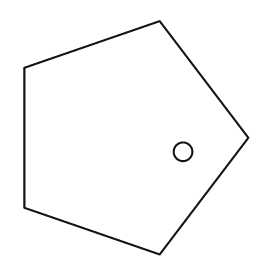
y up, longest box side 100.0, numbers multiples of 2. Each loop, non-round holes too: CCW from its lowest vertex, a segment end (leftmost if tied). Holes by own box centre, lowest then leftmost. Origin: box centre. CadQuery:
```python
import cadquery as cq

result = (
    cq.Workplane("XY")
    .moveTo(10.0, -50.0)
    .lineTo(48.0, 0.0)
    .lineTo(10.0, 50.0)
    .lineTo(-48.0, 30.0)
    .lineTo(-48.0, -30.0)
    .close()
    .moveTo(20.0, -6.0)
    .circle(4.0)
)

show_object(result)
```